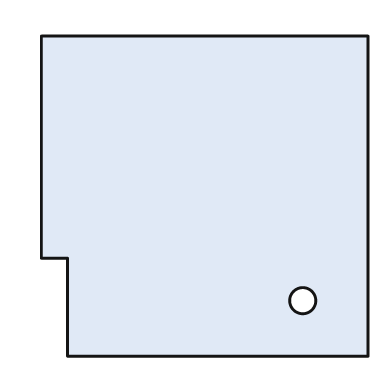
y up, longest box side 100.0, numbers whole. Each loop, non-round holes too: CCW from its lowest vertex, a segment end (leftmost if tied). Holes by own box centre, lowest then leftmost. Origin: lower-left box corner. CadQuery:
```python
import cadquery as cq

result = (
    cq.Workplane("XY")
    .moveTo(8.0, 0.0)
    .lineTo(100.0, 0.0)
    .lineTo(100.0, 98.0)
    .lineTo(0.0, 98.0)
    .lineTo(0.0, 30.0)
    .lineTo(8.0, 30.0)
    .close()
    .moveTo(80.0, 17.0)
    .circle(4.0)
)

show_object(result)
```